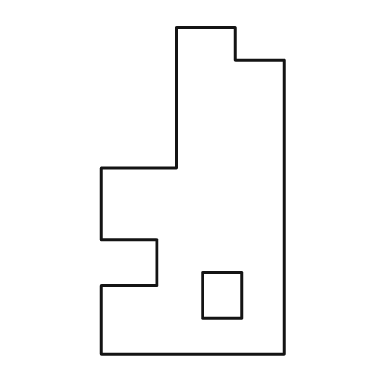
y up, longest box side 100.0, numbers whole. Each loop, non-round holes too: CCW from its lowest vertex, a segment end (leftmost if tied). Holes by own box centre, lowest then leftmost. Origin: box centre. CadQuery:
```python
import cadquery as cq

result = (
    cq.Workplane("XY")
    .moveTo(-28.0, -50.0)
    .lineTo(28.0, -50.0)
    .lineTo(28.0, 40.0)
    .lineTo(13.0, 40.0)
    .lineTo(13.0, 50.0)
    .lineTo(-5.0, 50.0)
    .lineTo(-5.0, 7.0)
    .lineTo(-28.0, 7.0)
    .lineTo(-28.0, -15.0)
    .lineTo(-11.0, -15.0)
    .lineTo(-11.0, -29.0)
    .lineTo(-28.0, -29.0)
    .close()
    .moveTo(3.0, -39.0)
    .lineTo(15.0, -39.0)
    .lineTo(15.0, -25.0)
    .lineTo(3.0, -25.0)
    .close()
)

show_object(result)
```